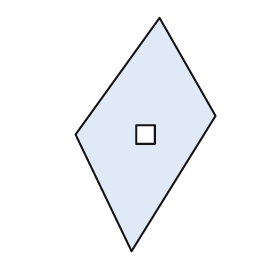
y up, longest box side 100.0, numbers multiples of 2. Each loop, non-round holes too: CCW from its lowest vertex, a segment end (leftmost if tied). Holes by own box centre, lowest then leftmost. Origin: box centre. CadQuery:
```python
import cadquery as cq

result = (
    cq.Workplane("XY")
    .moveTo(-6.0, -50.0)
    .lineTo(30.0, 8.0)
    .lineTo(6.0, 50.0)
    .lineTo(-30.0, 0.0)
    .close()
    .moveTo(-4.0, -4.0)
    .lineTo(4.0, -4.0)
    .lineTo(4.0, 4.0)
    .lineTo(-4.0, 4.0)
    .close()
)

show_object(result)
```